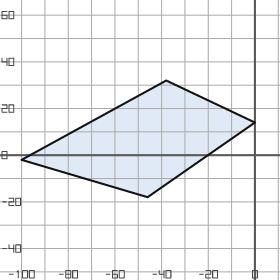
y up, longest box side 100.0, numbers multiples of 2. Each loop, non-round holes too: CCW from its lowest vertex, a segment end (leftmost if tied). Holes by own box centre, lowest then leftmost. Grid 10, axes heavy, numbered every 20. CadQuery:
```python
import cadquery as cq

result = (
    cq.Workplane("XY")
    .moveTo(-46.0, -18.0)
    .lineTo(0.0, 14.0)
    .lineTo(-38.0, 32.0)
    .lineTo(-100.0, -2.0)
    .close()
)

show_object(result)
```